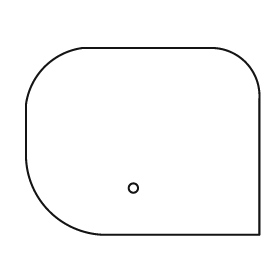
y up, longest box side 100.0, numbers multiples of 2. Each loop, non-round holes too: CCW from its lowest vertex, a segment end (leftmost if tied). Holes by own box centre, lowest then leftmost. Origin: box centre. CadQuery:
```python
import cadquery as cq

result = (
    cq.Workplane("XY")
    .moveTo(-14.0, -40.0)
    .lineTo(50.0, -40.0)
    .lineTo(50.0, 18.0)
    .threePointArc((44.0, 34.0), (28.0, 40.0))
    .lineTo(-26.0, 40.0)
    .threePointArc((-42.0, 32.0), (-50.0, 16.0))
    .lineTo(-50.0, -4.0)
    .threePointArc((-40.0, -30.0), (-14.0, -40.0))
    .close()
    .moveTo(-4.0, -20.0)
    .circle(2.0)
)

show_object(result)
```